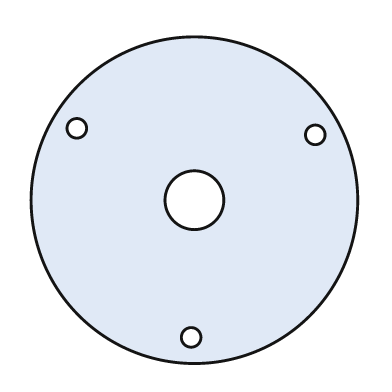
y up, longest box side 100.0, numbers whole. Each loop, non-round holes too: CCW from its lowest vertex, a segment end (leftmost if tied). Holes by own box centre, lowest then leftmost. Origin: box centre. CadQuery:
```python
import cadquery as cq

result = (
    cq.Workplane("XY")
    .moveTo(0.0, 0.0)
    .circle(50.0)
    .moveTo(-1.0, -42.0)
    .circle(3.0)
    .moveTo(0.0, 0.0)
    .circle(9.0)
    .moveTo(37.0, 20.0)
    .circle(3.0)
    .moveTo(-36.0, 22.0)
    .circle(3.0)
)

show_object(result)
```